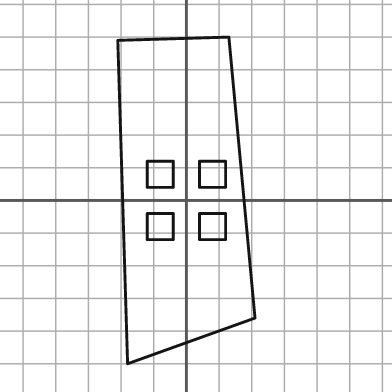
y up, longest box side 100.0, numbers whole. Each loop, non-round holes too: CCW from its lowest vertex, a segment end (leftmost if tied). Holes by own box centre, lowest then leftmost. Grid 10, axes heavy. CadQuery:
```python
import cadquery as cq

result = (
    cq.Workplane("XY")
    .moveTo(-18.0, -50.0)
    .lineTo(21.0, -36.0)
    .lineTo(13.0, 50.0)
    .lineTo(-21.0, 49.0)
    .close()
    .moveTo(-12.0, -12.0)
    .lineTo(-4.0, -12.0)
    .lineTo(-4.0, -4.0)
    .lineTo(-12.0, -4.0)
    .close()
    .moveTo(4.0, -12.0)
    .lineTo(12.0, -12.0)
    .lineTo(12.0, -4.0)
    .lineTo(4.0, -4.0)
    .close()
    .moveTo(-12.0, 4.0)
    .lineTo(-4.0, 4.0)
    .lineTo(-4.0, 12.0)
    .lineTo(-12.0, 12.0)
    .close()
    .moveTo(4.0, 4.0)
    .lineTo(12.0, 4.0)
    .lineTo(12.0, 12.0)
    .lineTo(4.0, 12.0)
    .close()
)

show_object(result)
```